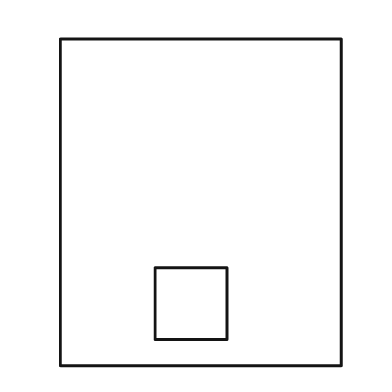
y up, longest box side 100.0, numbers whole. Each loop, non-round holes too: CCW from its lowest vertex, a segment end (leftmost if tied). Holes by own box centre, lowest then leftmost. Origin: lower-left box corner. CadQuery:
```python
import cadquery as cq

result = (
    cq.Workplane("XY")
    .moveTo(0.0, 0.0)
    .lineTo(86.0, 0.0)
    .lineTo(86.0, 100.0)
    .lineTo(0.0, 100.0)
    .close()
    .moveTo(29.0, 8.0)
    .lineTo(51.0, 8.0)
    .lineTo(51.0, 30.0)
    .lineTo(29.0, 30.0)
    .close()
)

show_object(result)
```